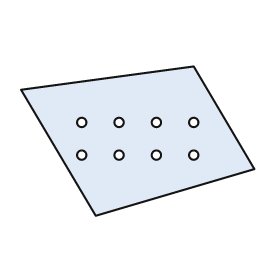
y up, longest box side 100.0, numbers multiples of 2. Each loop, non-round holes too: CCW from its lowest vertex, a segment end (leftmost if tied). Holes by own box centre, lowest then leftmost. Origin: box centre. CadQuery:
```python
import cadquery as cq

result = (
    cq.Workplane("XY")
    .moveTo(-18.0, -32.0)
    .lineTo(50.0, -12.0)
    .lineTo(24.0, 32.0)
    .lineTo(-50.0, 22.0)
    .close()
    .moveTo(-24.0, -6.0)
    .circle(2.0)
    .moveTo(-8.0, -6.0)
    .circle(2.0)
    .moveTo(8.0, -6.0)
    .circle(2.0)
    .moveTo(24.0, -6.0)
    .circle(2.0)
    .moveTo(-24.0, 8.0)
    .circle(2.0)
    .moveTo(-8.0, 8.0)
    .circle(2.0)
    .moveTo(8.0, 8.0)
    .circle(2.0)
    .moveTo(24.0, 8.0)
    .circle(2.0)
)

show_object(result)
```